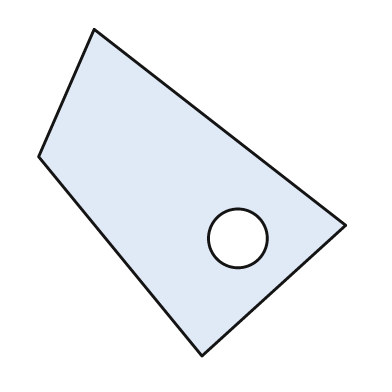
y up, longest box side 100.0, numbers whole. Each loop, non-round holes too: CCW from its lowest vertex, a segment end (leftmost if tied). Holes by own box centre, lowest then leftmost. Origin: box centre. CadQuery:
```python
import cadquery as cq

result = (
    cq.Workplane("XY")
    .moveTo(3.0, -50.0)
    .lineTo(47.0, -10.0)
    .lineTo(-30.0, 50.0)
    .lineTo(-47.0, 11.0)
    .close()
    .moveTo(14.0, -14.0)
    .circle(9.0)
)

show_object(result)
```